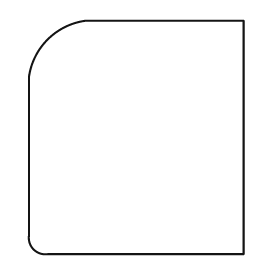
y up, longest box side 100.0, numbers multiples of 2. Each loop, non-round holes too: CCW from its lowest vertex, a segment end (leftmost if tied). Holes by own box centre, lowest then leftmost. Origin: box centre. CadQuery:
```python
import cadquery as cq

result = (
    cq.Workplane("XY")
    .moveTo(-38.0, -50.0)
    .lineTo(46.0, -50.0)
    .lineTo(46.0, 50.0)
    .lineTo(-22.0, 50.0)
    .threePointArc((-38.0, 42.0), (-46.0, 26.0))
    .lineTo(-46.0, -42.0)
    .threePointArc((-44.0, -48.0), (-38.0, -50.0))
    .close()
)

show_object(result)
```